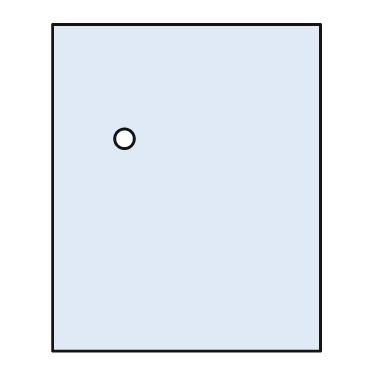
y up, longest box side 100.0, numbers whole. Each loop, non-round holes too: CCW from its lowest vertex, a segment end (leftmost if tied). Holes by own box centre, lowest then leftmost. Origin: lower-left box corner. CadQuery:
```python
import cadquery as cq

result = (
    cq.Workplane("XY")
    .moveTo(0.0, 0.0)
    .lineTo(82.0, 0.0)
    .lineTo(82.0, 100.0)
    .lineTo(0.0, 100.0)
    .close()
    .moveTo(22.0, 65.0)
    .circle(3.0)
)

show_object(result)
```